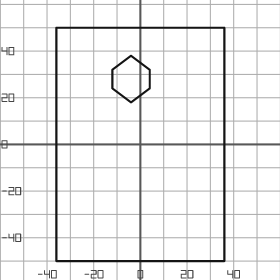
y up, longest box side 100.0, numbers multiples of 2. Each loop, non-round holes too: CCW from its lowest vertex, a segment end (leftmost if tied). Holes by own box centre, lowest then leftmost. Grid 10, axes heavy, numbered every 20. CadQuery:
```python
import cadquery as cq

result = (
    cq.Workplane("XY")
    .moveTo(-36.0, -50.0)
    .lineTo(36.0, -50.0)
    .lineTo(36.0, 50.0)
    .lineTo(-36.0, 50.0)
    .close()
    .moveTo(-4.0, 18.0)
    .lineTo(4.0, 24.0)
    .lineTo(4.0, 32.0)
    .lineTo(-4.0, 38.0)
    .lineTo(-12.0, 32.0)
    .lineTo(-12.0, 24.0)
    .close()
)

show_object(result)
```